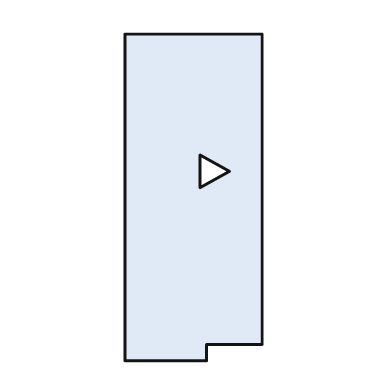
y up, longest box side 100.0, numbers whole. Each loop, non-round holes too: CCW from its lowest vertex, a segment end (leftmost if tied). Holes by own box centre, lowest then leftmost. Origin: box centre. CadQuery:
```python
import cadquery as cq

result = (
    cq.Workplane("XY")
    .moveTo(-21.0, -50.0)
    .lineTo(4.0, -50.0)
    .lineTo(4.0, -45.0)
    .lineTo(21.0, -45.0)
    .lineTo(21.0, 50.0)
    .lineTo(-21.0, 50.0)
    .close()
    .moveTo(2.0, 3.0)
    .lineTo(11.0, 8.0)
    .lineTo(2.0, 13.0)
    .close()
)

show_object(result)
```